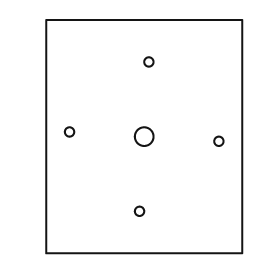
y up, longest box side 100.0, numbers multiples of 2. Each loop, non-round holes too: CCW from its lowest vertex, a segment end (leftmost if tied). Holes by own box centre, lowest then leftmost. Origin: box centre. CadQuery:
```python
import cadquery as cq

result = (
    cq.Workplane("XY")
    .moveTo(-42.0, -50.0)
    .lineTo(42.0, -50.0)
    .lineTo(42.0, 50.0)
    .lineTo(-42.0, 50.0)
    .close()
    .moveTo(-2.0, -32.0)
    .circle(2.0)
    .moveTo(32.0, -2.0)
    .circle(2.0)
    .moveTo(0.0, 0.0)
    .circle(4.0)
    .moveTo(-32.0, 2.0)
    .circle(2.0)
    .moveTo(2.0, 32.0)
    .circle(2.0)
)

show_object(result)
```